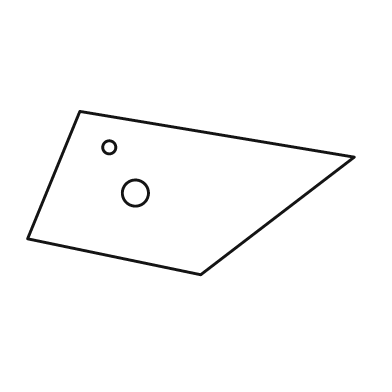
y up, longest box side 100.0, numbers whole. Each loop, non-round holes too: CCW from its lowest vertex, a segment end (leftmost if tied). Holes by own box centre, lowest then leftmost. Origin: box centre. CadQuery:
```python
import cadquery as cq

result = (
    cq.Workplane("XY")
    .moveTo(3.0, -25.0)
    .lineTo(50.0, 11.0)
    .lineTo(-34.0, 25.0)
    .lineTo(-50.0, -14.0)
    .close()
    .moveTo(-17.0, 0.0)
    .circle(4.0)
    .moveTo(-25.0, 14.0)
    .circle(2.0)
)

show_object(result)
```